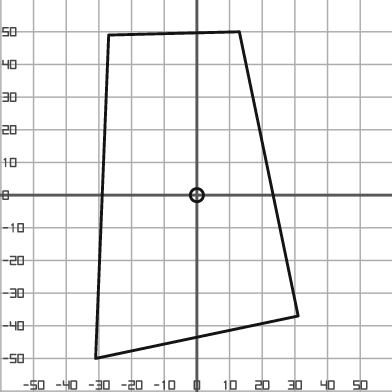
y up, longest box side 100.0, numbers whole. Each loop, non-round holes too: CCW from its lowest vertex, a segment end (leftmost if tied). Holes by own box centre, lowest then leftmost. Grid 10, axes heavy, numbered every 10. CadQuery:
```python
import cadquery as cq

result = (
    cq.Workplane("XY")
    .moveTo(-31.0, -50.0)
    .lineTo(31.0, -37.0)
    .lineTo(13.0, 50.0)
    .lineTo(-27.0, 49.0)
    .close()
    .moveTo(0.0, 0.0)
    .circle(2.0)
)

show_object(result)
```